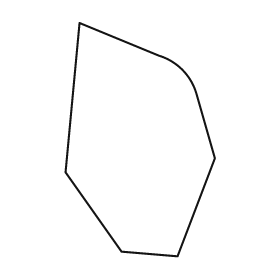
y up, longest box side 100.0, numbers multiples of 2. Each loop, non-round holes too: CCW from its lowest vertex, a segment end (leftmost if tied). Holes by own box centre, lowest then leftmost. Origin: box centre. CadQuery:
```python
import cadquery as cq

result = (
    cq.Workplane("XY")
    .moveTo(16.0, -50.0)
    .lineTo(32.0, -8.0)
    .lineTo(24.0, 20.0)
    .threePointArc((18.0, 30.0), (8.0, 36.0))
    .lineTo(-26.0, 50.0)
    .lineTo(-32.0, -14.0)
    .lineTo(-8.0, -48.0)
    .close()
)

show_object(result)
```